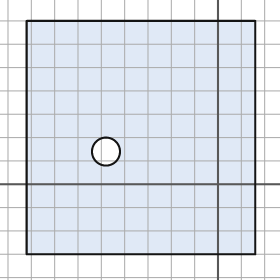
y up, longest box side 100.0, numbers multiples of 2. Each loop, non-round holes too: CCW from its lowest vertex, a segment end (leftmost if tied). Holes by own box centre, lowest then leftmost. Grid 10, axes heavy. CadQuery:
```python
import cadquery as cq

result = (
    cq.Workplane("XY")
    .moveTo(-82.0, -30.0)
    .lineTo(16.0, -30.0)
    .lineTo(16.0, 70.0)
    .lineTo(-82.0, 70.0)
    .close()
    .moveTo(-48.0, 14.0)
    .circle(6.0)
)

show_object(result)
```